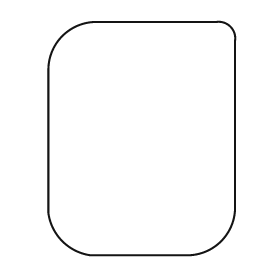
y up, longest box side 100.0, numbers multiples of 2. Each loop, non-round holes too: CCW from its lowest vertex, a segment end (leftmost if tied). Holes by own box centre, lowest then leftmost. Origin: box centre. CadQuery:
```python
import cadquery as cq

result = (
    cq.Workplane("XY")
    .moveTo(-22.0, -50.0)
    .lineTo(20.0, -50.0)
    .threePointArc((34.0, -44.0), (40.0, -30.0))
    .lineTo(40.0, 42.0)
    .threePointArc((38.0, 48.0), (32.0, 50.0))
    .lineTo(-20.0, 50.0)
    .threePointArc((-34.0, 44.0), (-40.0, 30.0))
    .lineTo(-40.0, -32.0)
    .threePointArc((-34.0, -44.0), (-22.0, -50.0))
    .close()
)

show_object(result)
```